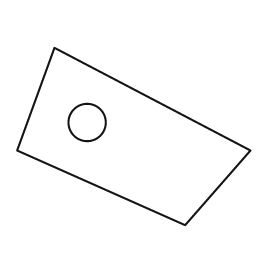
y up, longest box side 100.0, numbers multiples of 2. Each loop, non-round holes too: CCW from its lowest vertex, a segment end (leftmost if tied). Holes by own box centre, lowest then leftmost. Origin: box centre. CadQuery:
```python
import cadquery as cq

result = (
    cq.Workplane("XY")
    .moveTo(22.0, -38.0)
    .lineTo(50.0, -6.0)
    .lineTo(-34.0, 38.0)
    .lineTo(-50.0, -6.0)
    .close()
    .moveTo(-20.0, 6.0)
    .circle(8.0)
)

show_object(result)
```